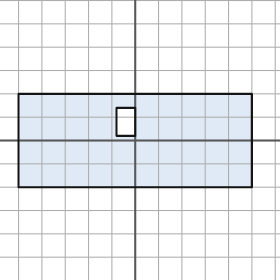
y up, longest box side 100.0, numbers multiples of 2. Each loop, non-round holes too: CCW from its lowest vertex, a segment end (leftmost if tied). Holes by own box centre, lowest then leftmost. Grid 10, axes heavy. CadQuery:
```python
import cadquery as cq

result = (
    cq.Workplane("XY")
    .moveTo(-50.0, -20.0)
    .lineTo(50.0, -20.0)
    .lineTo(50.0, 20.0)
    .lineTo(-50.0, 20.0)
    .close()
    .moveTo(-8.0, 2.0)
    .lineTo(0.0, 2.0)
    .lineTo(0.0, 14.0)
    .lineTo(-8.0, 14.0)
    .close()
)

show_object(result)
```